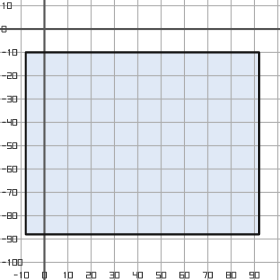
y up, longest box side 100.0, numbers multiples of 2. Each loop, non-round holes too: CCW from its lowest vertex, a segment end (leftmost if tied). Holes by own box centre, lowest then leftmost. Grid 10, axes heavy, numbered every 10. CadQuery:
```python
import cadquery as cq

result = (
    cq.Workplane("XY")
    .moveTo(-8.0, -88.0)
    .lineTo(92.0, -88.0)
    .lineTo(92.0, -10.0)
    .lineTo(-8.0, -10.0)
    .close()
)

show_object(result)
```